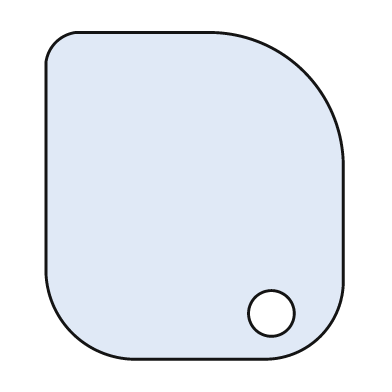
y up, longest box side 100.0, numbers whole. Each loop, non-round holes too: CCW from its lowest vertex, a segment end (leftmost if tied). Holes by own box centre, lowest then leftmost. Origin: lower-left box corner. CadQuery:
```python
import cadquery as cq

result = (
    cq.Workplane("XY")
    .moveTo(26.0, 0.0)
    .lineTo(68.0, 0.0)
    .threePointArc((84.0, 7.0), (91.0, 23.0))
    .lineTo(91.0, 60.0)
    .threePointArc((79.0, 88.0), (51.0, 100.0))
    .lineTo(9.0, 100.0)
    .threePointArc((3.0, 97.0), (0.0, 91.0))
    .lineTo(0.0, 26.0)
    .threePointArc((8.0, 8.0), (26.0, 0.0))
    .close()
    .moveTo(69.0, 14.0)
    .circle(7.0)
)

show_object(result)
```